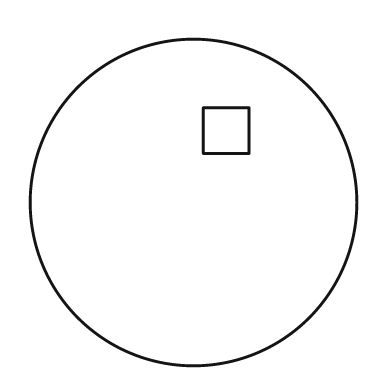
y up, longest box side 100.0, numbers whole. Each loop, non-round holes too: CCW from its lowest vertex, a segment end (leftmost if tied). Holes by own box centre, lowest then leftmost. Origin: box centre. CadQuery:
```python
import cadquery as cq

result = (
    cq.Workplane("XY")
    .moveTo(0.0, 0.0)
    .circle(50.0)
    .moveTo(3.0, 15.0)
    .lineTo(17.0, 15.0)
    .lineTo(17.0, 29.0)
    .lineTo(3.0, 29.0)
    .close()
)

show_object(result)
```